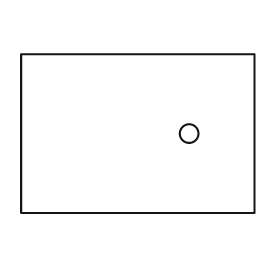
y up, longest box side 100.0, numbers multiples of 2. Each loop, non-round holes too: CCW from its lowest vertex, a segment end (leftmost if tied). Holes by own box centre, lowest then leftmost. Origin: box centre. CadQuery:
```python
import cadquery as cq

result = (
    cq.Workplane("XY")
    .moveTo(-50.0, -34.0)
    .lineTo(50.0, -34.0)
    .lineTo(50.0, 34.0)
    .lineTo(-50.0, 34.0)
    .close()
    .moveTo(22.0, 0.0)
    .circle(4.0)
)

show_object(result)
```